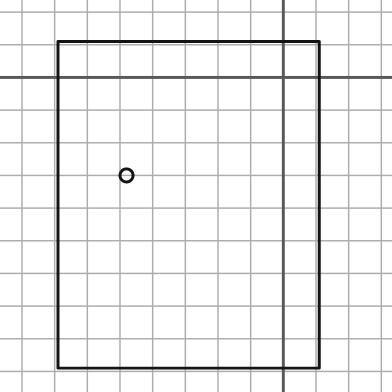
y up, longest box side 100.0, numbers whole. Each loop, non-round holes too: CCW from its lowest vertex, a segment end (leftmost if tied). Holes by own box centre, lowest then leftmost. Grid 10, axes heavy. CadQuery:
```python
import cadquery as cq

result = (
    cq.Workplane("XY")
    .moveTo(-69.0, -89.0)
    .lineTo(11.0, -89.0)
    .lineTo(11.0, 11.0)
    .lineTo(-69.0, 11.0)
    .close()
    .moveTo(-48.0, -30.0)
    .circle(2.0)
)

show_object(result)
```